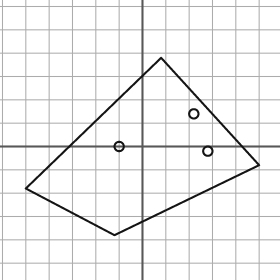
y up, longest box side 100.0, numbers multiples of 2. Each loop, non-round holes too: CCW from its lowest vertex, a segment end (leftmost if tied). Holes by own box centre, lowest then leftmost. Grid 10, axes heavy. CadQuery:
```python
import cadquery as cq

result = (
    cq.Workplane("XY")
    .moveTo(-12.0, -38.0)
    .lineTo(50.0, -8.0)
    .lineTo(8.0, 38.0)
    .lineTo(-50.0, -18.0)
    .close()
    .moveTo(28.0, -2.0)
    .circle(2.0)
    .moveTo(-10.0, 0.0)
    .circle(2.0)
    .moveTo(22.0, 14.0)
    .circle(2.0)
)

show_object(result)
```